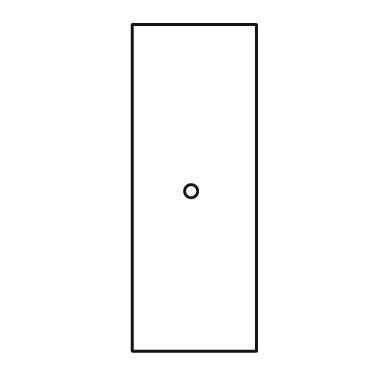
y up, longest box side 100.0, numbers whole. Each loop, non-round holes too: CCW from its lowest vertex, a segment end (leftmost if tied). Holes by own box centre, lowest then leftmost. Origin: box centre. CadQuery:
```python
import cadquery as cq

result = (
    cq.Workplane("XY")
    .moveTo(-19.0, -50.0)
    .lineTo(19.0, -50.0)
    .lineTo(19.0, 50.0)
    .lineTo(-19.0, 50.0)
    .close()
    .moveTo(-1.0, -1.0)
    .circle(2.0)
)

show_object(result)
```